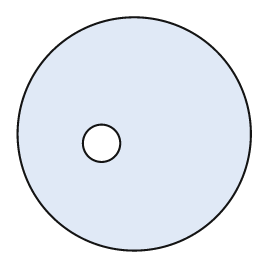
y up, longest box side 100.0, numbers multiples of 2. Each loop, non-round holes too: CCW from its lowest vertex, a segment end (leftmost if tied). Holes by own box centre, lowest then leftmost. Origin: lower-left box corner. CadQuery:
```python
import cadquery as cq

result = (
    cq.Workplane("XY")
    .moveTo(50.0, 50.0)
    .circle(50.0)
    .moveTo(36.0, 46.0)
    .circle(8.0)
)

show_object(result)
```